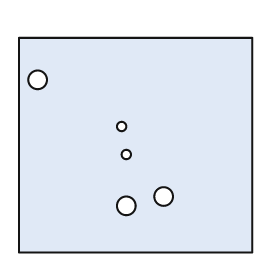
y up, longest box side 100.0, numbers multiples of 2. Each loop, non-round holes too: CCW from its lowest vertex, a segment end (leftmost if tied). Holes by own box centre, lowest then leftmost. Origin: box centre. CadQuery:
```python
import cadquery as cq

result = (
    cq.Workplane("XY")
    .moveTo(-50.0, -46.0)
    .lineTo(50.0, -46.0)
    .lineTo(50.0, 46.0)
    .lineTo(-50.0, 46.0)
    .close()
    .moveTo(-4.0, -26.0)
    .circle(4.0)
    .moveTo(12.0, -22.0)
    .circle(4.0)
    .moveTo(-4.0, -4.0)
    .circle(2.0)
    .moveTo(-6.0, 8.0)
    .circle(2.0)
    .moveTo(-42.0, 28.0)
    .circle(4.0)
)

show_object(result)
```